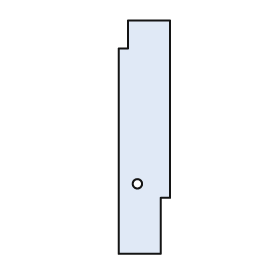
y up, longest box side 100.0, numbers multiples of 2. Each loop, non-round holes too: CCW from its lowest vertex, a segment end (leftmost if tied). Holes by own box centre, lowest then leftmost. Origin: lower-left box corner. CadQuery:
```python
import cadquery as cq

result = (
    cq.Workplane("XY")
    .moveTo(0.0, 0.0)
    .lineTo(18.0, 0.0)
    .lineTo(18.0, 24.0)
    .lineTo(22.0, 24.0)
    .lineTo(22.0, 100.0)
    .lineTo(4.0, 100.0)
    .lineTo(4.0, 88.0)
    .lineTo(0.0, 88.0)
    .close()
    .moveTo(8.0, 30.0)
    .circle(2.0)
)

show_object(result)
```